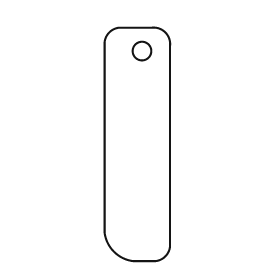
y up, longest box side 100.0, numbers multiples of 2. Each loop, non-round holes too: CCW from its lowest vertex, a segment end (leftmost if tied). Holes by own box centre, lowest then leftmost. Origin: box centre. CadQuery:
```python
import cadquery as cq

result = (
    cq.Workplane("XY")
    .moveTo(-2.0, -50.0)
    .lineTo(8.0, -50.0)
    .threePointArc((12.0, -48.0), (14.0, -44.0))
    .lineTo(14.0, 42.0)
    .threePointArc((12.0, 48.0), (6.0, 50.0))
    .lineTo(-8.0, 50.0)
    .threePointArc((-12.0, 48.0), (-14.0, 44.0))
    .lineTo(-14.0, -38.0)
    .threePointArc((-10.0, -46.0), (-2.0, -50.0))
    .close()
    .moveTo(2.0, 40.0)
    .circle(4.0)
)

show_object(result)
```